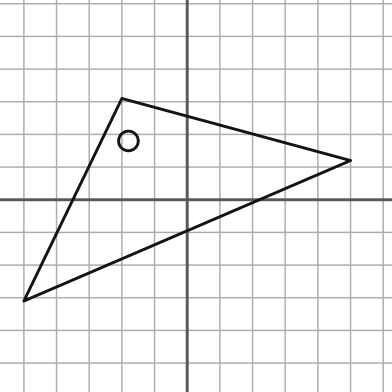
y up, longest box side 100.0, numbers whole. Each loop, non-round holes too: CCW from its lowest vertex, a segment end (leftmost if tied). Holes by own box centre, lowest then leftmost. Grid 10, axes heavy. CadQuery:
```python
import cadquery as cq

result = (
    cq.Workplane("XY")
    .moveTo(-50.0, -31.0)
    .lineTo(50.0, 12.0)
    .lineTo(-20.0, 31.0)
    .close()
    .moveTo(-18.0, 18.0)
    .circle(3.0)
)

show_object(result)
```